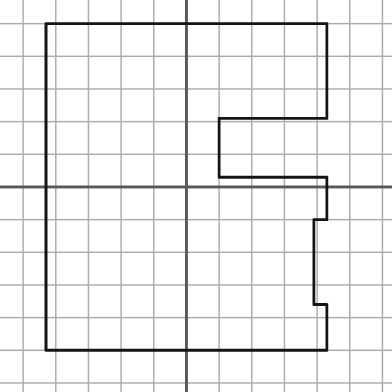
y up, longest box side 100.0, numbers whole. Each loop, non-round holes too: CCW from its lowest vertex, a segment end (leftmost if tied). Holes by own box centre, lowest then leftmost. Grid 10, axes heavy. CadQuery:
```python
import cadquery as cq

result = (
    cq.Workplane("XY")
    .moveTo(-43.0, -50.0)
    .lineTo(43.0, -50.0)
    .lineTo(43.0, -36.0)
    .lineTo(39.0, -36.0)
    .lineTo(39.0, -10.0)
    .lineTo(43.0, -10.0)
    .lineTo(43.0, 3.0)
    .lineTo(10.0, 3.0)
    .lineTo(10.0, 21.0)
    .lineTo(43.0, 21.0)
    .lineTo(43.0, 50.0)
    .lineTo(-43.0, 50.0)
    .close()
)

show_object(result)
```